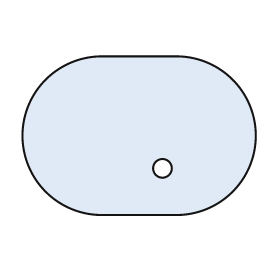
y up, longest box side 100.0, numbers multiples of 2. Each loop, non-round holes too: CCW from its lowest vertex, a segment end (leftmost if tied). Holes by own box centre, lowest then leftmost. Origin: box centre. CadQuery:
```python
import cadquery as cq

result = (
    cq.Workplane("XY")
    .moveTo(-16.0, -34.0)
    .lineTo(16.0, -34.0)
    .threePointArc((50.0, 0.0), (16.0, 34.0))
    .lineTo(-16.0, 34.0)
    .threePointArc((-50.0, 0.0), (-16.0, -34.0))
    .close()
    .moveTo(10.0, -14.0)
    .circle(4.0)
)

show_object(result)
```